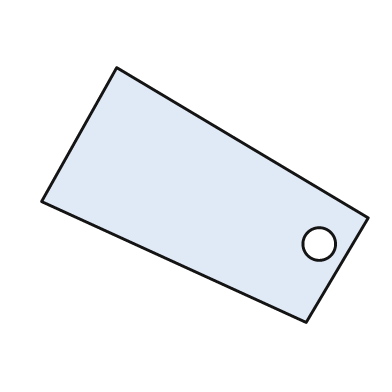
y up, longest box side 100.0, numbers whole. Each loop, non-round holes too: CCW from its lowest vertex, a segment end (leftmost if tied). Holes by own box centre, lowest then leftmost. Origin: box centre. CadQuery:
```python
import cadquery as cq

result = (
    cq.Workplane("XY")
    .moveTo(31.0, -39.0)
    .lineTo(50.0, -7.0)
    .lineTo(-27.0, 39.0)
    .lineTo(-50.0, -2.0)
    .close()
    .moveTo(35.0, -15.0)
    .circle(5.0)
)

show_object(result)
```